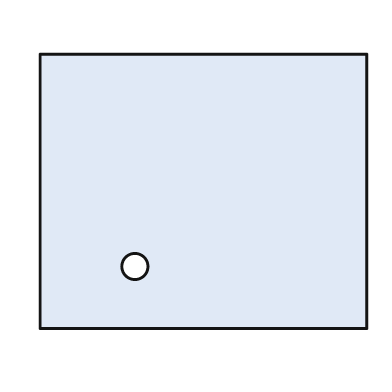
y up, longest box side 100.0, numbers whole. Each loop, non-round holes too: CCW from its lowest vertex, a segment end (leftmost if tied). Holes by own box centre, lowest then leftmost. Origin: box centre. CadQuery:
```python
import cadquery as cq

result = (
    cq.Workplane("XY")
    .moveTo(-50.0, -42.0)
    .lineTo(50.0, -42.0)
    .lineTo(50.0, 42.0)
    .lineTo(-50.0, 42.0)
    .close()
    .moveTo(-21.0, -23.0)
    .circle(4.0)
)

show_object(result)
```